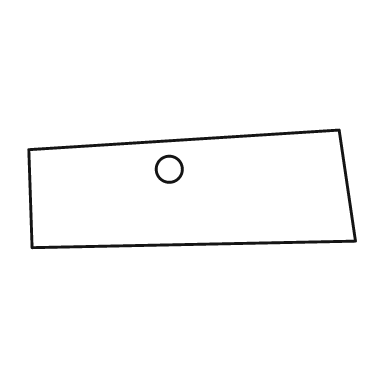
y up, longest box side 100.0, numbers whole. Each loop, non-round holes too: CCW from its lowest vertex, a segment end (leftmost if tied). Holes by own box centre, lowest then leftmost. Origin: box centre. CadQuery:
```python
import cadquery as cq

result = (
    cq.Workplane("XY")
    .moveTo(-49.0, -18.0)
    .lineTo(50.0, -16.0)
    .lineTo(45.0, 18.0)
    .lineTo(-50.0, 12.0)
    .close()
    .moveTo(-7.0, 6.0)
    .circle(4.0)
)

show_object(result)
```